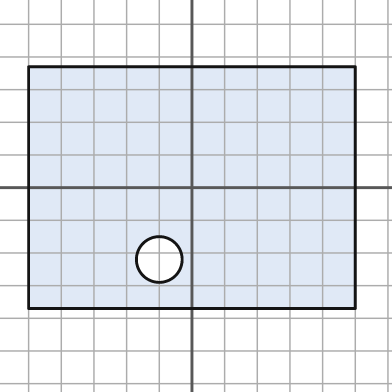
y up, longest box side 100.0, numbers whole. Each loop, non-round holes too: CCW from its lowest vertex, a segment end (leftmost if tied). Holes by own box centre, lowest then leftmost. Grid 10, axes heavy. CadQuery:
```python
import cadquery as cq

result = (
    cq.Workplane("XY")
    .moveTo(-50.0, -37.0)
    .lineTo(50.0, -37.0)
    .lineTo(50.0, 37.0)
    .lineTo(-50.0, 37.0)
    .close()
    .moveTo(-10.0, -22.0)
    .circle(7.0)
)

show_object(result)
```